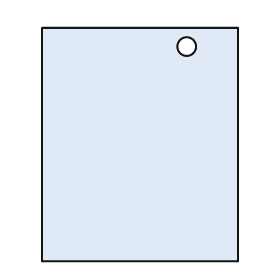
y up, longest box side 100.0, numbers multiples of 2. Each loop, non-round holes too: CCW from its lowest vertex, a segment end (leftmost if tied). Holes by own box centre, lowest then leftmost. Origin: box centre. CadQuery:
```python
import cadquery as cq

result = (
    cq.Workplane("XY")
    .moveTo(-42.0, -50.0)
    .lineTo(42.0, -50.0)
    .lineTo(42.0, 50.0)
    .lineTo(-42.0, 50.0)
    .close()
    .moveTo(20.0, 42.0)
    .circle(4.0)
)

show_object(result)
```